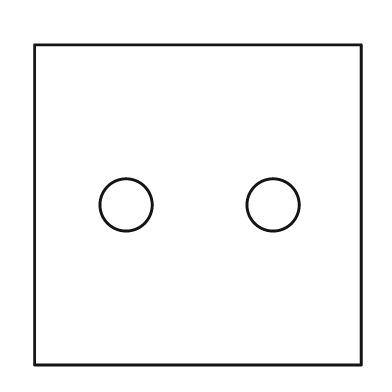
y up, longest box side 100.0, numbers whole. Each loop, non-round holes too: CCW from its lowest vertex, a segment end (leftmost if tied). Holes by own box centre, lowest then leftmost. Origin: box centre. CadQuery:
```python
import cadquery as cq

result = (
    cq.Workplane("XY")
    .moveTo(-50.0, -49.0)
    .lineTo(50.0, -49.0)
    .lineTo(50.0, 49.0)
    .lineTo(-50.0, 49.0)
    .close()
    .moveTo(-22.0, 0.0)
    .circle(8.0)
    .moveTo(23.0, 0.0)
    .circle(8.0)
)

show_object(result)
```